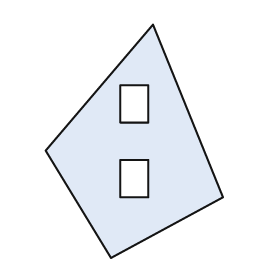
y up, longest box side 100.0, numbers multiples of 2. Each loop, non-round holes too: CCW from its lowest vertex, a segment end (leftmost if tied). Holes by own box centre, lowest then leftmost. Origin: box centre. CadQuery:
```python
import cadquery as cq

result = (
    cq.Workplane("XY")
    .moveTo(-10.0, -50.0)
    .lineTo(38.0, -24.0)
    .lineTo(8.0, 50.0)
    .lineTo(-38.0, -4.0)
    .close()
    .moveTo(-6.0, -24.0)
    .lineTo(6.0, -24.0)
    .lineTo(6.0, -8.0)
    .lineTo(-6.0, -8.0)
    .close()
    .moveTo(-6.0, 8.0)
    .lineTo(6.0, 8.0)
    .lineTo(6.0, 24.0)
    .lineTo(-6.0, 24.0)
    .close()
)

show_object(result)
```